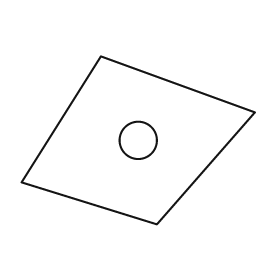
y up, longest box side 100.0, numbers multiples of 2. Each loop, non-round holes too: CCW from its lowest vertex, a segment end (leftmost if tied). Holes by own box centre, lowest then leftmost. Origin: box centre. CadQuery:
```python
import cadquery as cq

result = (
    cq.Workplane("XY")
    .moveTo(8.0, -36.0)
    .lineTo(50.0, 12.0)
    .lineTo(-16.0, 36.0)
    .lineTo(-50.0, -18.0)
    .close()
    .moveTo(0.0, 0.0)
    .circle(8.0)
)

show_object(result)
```